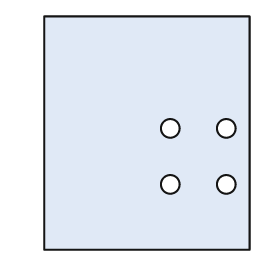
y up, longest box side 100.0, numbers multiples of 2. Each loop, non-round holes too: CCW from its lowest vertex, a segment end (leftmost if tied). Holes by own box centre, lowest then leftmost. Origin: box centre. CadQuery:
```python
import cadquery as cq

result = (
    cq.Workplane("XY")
    .moveTo(-44.0, -50.0)
    .lineTo(44.0, -50.0)
    .lineTo(44.0, 50.0)
    .lineTo(-44.0, 50.0)
    .close()
    .moveTo(10.0, -22.0)
    .circle(4.0)
    .moveTo(34.0, -22.0)
    .circle(4.0)
    .moveTo(10.0, 2.0)
    .circle(4.0)
    .moveTo(34.0, 2.0)
    .circle(4.0)
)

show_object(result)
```